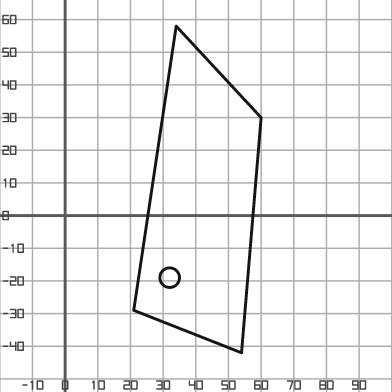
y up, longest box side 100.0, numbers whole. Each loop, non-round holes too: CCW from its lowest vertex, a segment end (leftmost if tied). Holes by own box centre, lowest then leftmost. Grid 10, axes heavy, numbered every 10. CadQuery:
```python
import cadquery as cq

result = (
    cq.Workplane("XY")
    .moveTo(54.0, -42.0)
    .lineTo(60.0, 30.0)
    .lineTo(34.0, 58.0)
    .lineTo(21.0, -29.0)
    .close()
    .moveTo(32.0, -19.0)
    .circle(3.0)
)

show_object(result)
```